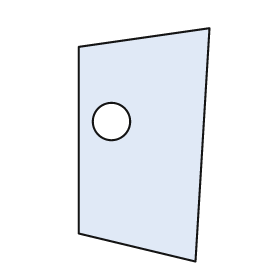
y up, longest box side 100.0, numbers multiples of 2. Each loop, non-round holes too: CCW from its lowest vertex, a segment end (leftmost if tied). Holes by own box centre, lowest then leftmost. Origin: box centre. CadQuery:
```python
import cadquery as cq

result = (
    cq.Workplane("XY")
    .moveTo(22.0, -50.0)
    .lineTo(28.0, 50.0)
    .lineTo(-28.0, 42.0)
    .lineTo(-28.0, -38.0)
    .close()
    .moveTo(-14.0, 10.0)
    .circle(8.0)
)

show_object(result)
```